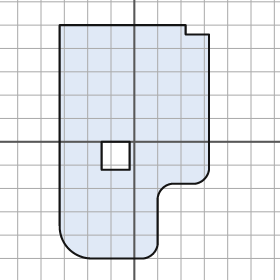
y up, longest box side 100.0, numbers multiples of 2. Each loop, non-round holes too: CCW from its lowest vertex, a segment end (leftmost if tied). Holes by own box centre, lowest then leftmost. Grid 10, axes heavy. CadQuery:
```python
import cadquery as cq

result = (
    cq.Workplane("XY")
    .moveTo(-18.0, -50.0)
    .lineTo(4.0, -50.0)
    .threePointArc((8.0, -48.0), (10.0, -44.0))
    .lineTo(10.0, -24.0)
    .threePointArc((12.0, -20.0), (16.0, -18.0))
    .lineTo(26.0, -18.0)
    .threePointArc((30.0, -16.0), (32.0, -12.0))
    .lineTo(32.0, 46.0)
    .lineTo(22.0, 46.0)
    .lineTo(22.0, 50.0)
    .lineTo(-32.0, 50.0)
    .lineTo(-32.0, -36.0)
    .threePointArc((-28.0, -46.0), (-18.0, -50.0))
    .close()
    .moveTo(-14.0, -12.0)
    .lineTo(-2.0, -12.0)
    .lineTo(-2.0, 0.0)
    .lineTo(-14.0, 0.0)
    .close()
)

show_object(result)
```